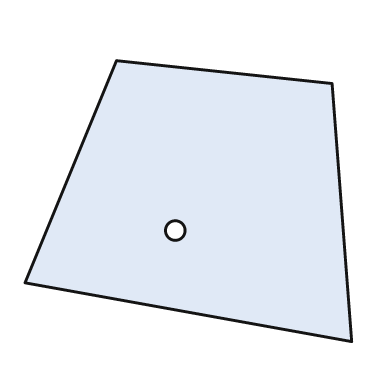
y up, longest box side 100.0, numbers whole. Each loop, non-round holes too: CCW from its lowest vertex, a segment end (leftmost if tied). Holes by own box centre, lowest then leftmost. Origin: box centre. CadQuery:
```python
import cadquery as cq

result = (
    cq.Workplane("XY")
    .moveTo(50.0, -43.0)
    .lineTo(44.0, 36.0)
    .lineTo(-22.0, 43.0)
    .lineTo(-50.0, -25.0)
    .close()
    .moveTo(-4.0, -9.0)
    .circle(3.0)
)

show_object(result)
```